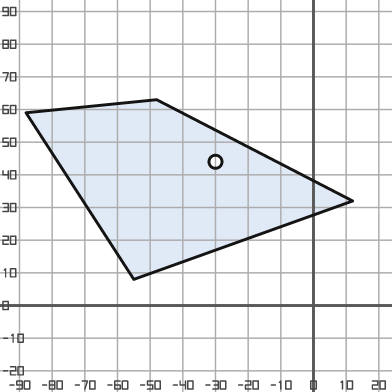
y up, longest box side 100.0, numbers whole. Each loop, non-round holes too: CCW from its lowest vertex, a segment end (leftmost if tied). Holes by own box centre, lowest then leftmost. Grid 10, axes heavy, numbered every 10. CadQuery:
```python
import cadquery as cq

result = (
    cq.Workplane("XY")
    .moveTo(-55.0, 8.0)
    .lineTo(12.0, 32.0)
    .lineTo(-48.0, 63.0)
    .lineTo(-88.0, 59.0)
    .close()
    .moveTo(-30.0, 44.0)
    .circle(2.0)
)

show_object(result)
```